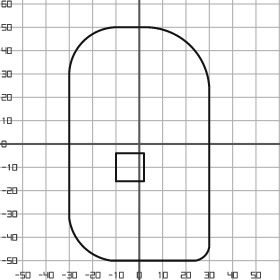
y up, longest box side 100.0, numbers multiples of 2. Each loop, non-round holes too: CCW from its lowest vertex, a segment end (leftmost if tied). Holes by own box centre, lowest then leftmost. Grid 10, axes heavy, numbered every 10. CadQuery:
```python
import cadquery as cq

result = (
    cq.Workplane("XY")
    .moveTo(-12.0, -50.0)
    .lineTo(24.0, -50.0)
    .threePointArc((28.0, -48.0), (30.0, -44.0))
    .lineTo(30.0, 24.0)
    .threePointArc((22.0, 42.0), (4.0, 50.0))
    .lineTo(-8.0, 50.0)
    .threePointArc((-24.0, 44.0), (-30.0, 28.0))
    .lineTo(-30.0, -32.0)
    .threePointArc((-24.0, -44.0), (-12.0, -50.0))
    .close()
    .moveTo(-10.0, -16.0)
    .lineTo(2.0, -16.0)
    .lineTo(2.0, -4.0)
    .lineTo(-10.0, -4.0)
    .close()
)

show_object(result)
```